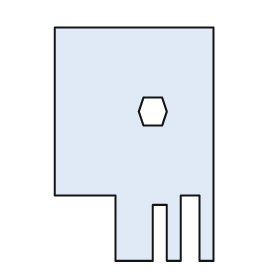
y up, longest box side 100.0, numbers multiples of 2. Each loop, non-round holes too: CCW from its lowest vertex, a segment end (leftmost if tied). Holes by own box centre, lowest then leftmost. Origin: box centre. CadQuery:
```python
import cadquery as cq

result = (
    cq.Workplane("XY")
    .moveTo(-8.0, -50.0)
    .lineTo(8.0, -50.0)
    .lineTo(8.0, -26.0)
    .lineTo(14.0, -26.0)
    .lineTo(14.0, -50.0)
    .lineTo(20.0, -50.0)
    .lineTo(20.0, -22.0)
    .lineTo(28.0, -22.0)
    .lineTo(28.0, -50.0)
    .lineTo(34.0, -50.0)
    .lineTo(34.0, 50.0)
    .lineTo(-34.0, 50.0)
    .lineTo(-34.0, -22.0)
    .lineTo(-8.0, -22.0)
    .close()
    .moveTo(4.0, 8.0)
    .lineTo(12.0, 8.0)
    .lineTo(14.0, 14.0)
    .lineTo(12.0, 20.0)
    .lineTo(4.0, 20.0)
    .lineTo(2.0, 14.0)
    .close()
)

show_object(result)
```